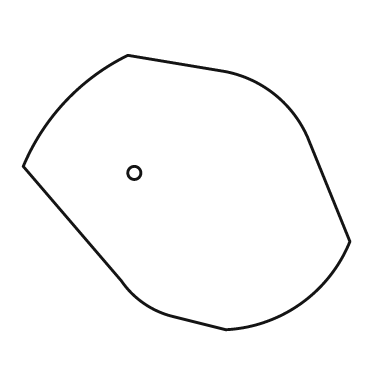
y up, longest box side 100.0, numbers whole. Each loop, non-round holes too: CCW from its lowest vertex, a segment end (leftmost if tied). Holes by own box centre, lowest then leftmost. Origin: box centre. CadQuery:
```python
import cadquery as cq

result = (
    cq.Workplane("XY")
    .moveTo(12.0, -42.0)
    .threePointArc((35.0, -34.0), (50.0, -15.0))
    .lineTo(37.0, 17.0)
    .threePointArc((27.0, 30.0), (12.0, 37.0))
    .lineTo(-18.0, 42.0)
    .threePointArc((-37.0, 28.0), (-50.0, 8.0))
    .lineTo(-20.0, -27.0)
    .threePointArc((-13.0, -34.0), (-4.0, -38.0))
    .close()
    .moveTo(-16.0, 6.0)
    .circle(2.0)
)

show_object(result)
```